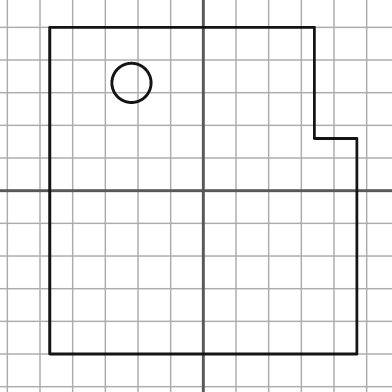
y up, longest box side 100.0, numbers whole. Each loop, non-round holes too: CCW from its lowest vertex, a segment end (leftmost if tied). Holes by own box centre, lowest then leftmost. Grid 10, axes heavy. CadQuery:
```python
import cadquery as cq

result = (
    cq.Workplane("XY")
    .moveTo(-47.0, -50.0)
    .lineTo(47.0, -50.0)
    .lineTo(47.0, 16.0)
    .lineTo(34.0, 16.0)
    .lineTo(34.0, 50.0)
    .lineTo(-47.0, 50.0)
    .close()
    .moveTo(-22.0, 33.0)
    .circle(6.0)
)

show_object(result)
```